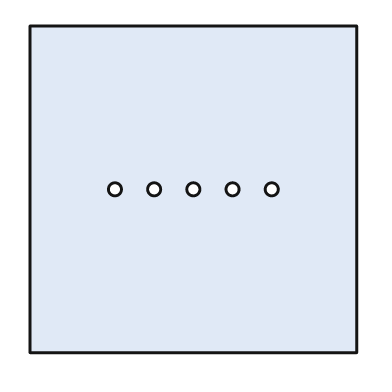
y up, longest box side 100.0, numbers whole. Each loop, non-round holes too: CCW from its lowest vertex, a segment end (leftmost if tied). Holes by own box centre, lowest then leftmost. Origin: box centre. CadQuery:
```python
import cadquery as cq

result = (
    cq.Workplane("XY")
    .moveTo(-50.0, -50.0)
    .lineTo(50.0, -50.0)
    .lineTo(50.0, 50.0)
    .lineTo(-50.0, 50.0)
    .close()
    .moveTo(-24.0, 0.0)
    .circle(2.0)
    .moveTo(-12.0, 0.0)
    .circle(2.0)
    .moveTo(0.0, 0.0)
    .circle(2.0)
    .moveTo(12.0, 0.0)
    .circle(2.0)
    .moveTo(24.0, 0.0)
    .circle(2.0)
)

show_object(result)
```